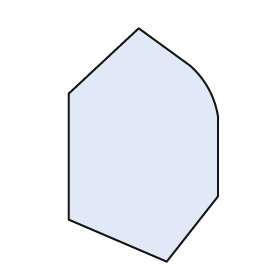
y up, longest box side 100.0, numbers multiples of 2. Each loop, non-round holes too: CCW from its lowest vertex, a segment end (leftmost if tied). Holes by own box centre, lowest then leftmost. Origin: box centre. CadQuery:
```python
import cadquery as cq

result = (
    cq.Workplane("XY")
    .moveTo(10.0, -50.0)
    .lineTo(32.0, -22.0)
    .lineTo(32.0, 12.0)
    .threePointArc((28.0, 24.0), (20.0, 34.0))
    .lineTo(-2.0, 50.0)
    .lineTo(-32.0, 22.0)
    .lineTo(-32.0, -32.0)
    .close()
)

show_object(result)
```